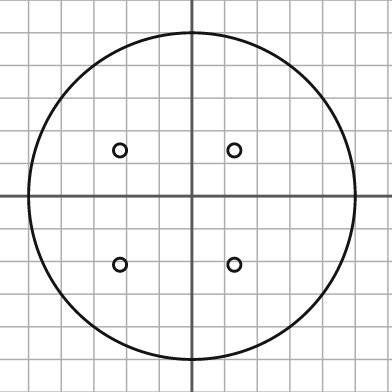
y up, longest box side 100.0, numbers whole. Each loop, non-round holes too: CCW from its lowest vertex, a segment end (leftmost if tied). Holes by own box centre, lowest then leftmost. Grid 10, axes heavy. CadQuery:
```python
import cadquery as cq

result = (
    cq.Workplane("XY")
    .moveTo(0.0, 0.0)
    .circle(50.0)
    .moveTo(-22.0, -21.0)
    .circle(2.0)
    .moveTo(13.0, -21.0)
    .circle(2.0)
    .moveTo(-22.0, 14.0)
    .circle(2.0)
    .moveTo(13.0, 14.0)
    .circle(2.0)
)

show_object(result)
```